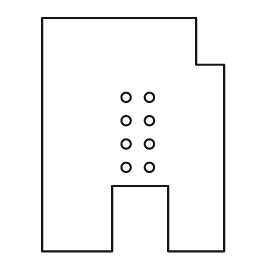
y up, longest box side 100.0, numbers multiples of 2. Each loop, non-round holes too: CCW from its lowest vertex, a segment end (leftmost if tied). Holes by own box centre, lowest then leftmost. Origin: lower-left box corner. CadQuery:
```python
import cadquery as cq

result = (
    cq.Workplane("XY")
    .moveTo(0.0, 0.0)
    .lineTo(30.0, 0.0)
    .lineTo(30.0, 28.0)
    .lineTo(54.0, 28.0)
    .lineTo(54.0, 0.0)
    .lineTo(78.0, 0.0)
    .lineTo(78.0, 80.0)
    .lineTo(66.0, 80.0)
    .lineTo(66.0, 100.0)
    .lineTo(0.0, 100.0)
    .close()
    .moveTo(36.0, 36.0)
    .circle(2.0)
    .moveTo(46.0, 36.0)
    .circle(2.0)
    .moveTo(36.0, 46.0)
    .circle(2.0)
    .moveTo(46.0, 46.0)
    .circle(2.0)
    .moveTo(36.0, 56.0)
    .circle(2.0)
    .moveTo(46.0, 56.0)
    .circle(2.0)
    .moveTo(36.0, 66.0)
    .circle(2.0)
    .moveTo(46.0, 66.0)
    .circle(2.0)
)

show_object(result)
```